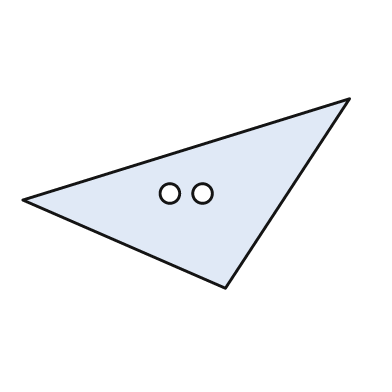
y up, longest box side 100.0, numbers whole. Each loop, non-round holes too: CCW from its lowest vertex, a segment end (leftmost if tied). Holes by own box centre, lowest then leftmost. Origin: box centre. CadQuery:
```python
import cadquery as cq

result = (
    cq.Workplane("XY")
    .moveTo(12.0, -29.0)
    .lineTo(50.0, 29.0)
    .lineTo(-50.0, -2.0)
    .close()
    .moveTo(-5.0, 0.0)
    .circle(3.0)
    .moveTo(5.0, 0.0)
    .circle(3.0)
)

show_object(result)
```